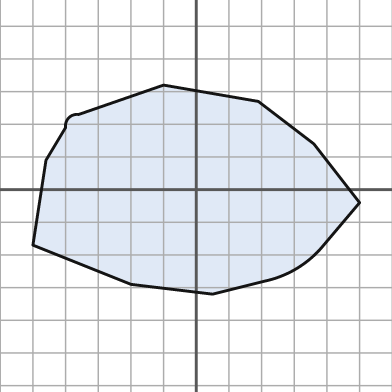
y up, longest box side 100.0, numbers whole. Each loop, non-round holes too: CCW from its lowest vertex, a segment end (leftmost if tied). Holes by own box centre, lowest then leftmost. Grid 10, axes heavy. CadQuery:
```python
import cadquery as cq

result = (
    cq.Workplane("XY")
    .moveTo(5.0, -32.0)
    .lineTo(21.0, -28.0)
    .threePointArc((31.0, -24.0), (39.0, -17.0))
    .lineTo(50.0, -4.0)
    .lineTo(36.0, 14.0)
    .lineTo(19.0, 27.0)
    .lineTo(-10.0, 32.0)
    .lineTo(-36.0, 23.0)
    .threePointArc((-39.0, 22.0), (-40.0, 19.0))
    .lineTo(-46.0, 9.0)
    .lineTo(-50.0, -17.0)
    .lineTo(-20.0, -29.0)
    .close()
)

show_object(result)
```